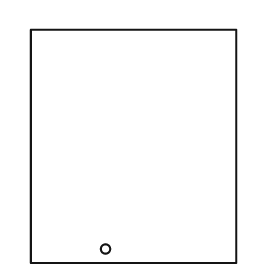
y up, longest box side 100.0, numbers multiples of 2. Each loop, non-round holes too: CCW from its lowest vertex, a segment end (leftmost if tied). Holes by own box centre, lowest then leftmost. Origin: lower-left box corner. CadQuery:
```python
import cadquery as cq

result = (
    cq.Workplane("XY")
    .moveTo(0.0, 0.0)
    .lineTo(88.0, 0.0)
    .lineTo(88.0, 100.0)
    .lineTo(0.0, 100.0)
    .close()
    .moveTo(32.0, 6.0)
    .circle(2.0)
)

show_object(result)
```